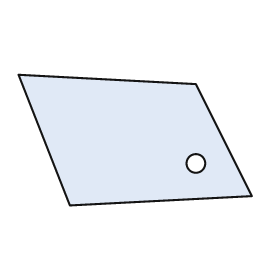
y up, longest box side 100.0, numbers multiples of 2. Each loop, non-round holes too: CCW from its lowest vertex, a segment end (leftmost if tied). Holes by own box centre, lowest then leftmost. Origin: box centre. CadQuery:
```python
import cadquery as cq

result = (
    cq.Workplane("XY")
    .moveTo(-28.0, -28.0)
    .lineTo(50.0, -24.0)
    .lineTo(26.0, 24.0)
    .lineTo(-50.0, 28.0)
    .close()
    .moveTo(26.0, -10.0)
    .circle(4.0)
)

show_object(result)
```